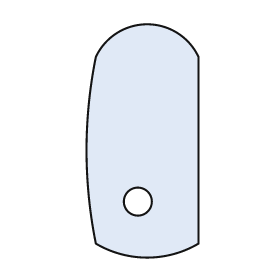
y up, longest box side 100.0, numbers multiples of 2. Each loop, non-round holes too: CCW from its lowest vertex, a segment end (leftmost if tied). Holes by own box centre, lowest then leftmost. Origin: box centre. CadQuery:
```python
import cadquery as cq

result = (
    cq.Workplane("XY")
    .moveTo(-20.0, -44.0)
    .threePointArc((2.0, -50.0), (24.0, -44.0))
    .lineTo(24.0, 36.0)
    .threePointArc((2.0, 50.0), (-20.0, 36.0))
    .threePointArc((-24.0, -4.0), (-20.0, -44.0))
    .close()
    .moveTo(-2.0, -26.0)
    .circle(6.0)
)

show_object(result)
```